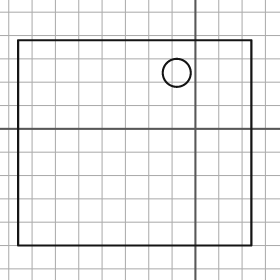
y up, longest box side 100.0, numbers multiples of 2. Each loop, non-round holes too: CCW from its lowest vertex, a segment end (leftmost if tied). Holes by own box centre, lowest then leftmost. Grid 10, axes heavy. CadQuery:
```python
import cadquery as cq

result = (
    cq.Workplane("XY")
    .moveTo(-76.0, -50.0)
    .lineTo(24.0, -50.0)
    .lineTo(24.0, 38.0)
    .lineTo(-76.0, 38.0)
    .close()
    .moveTo(-8.0, 24.0)
    .circle(6.0)
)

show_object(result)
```